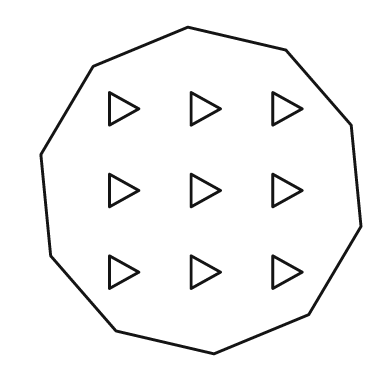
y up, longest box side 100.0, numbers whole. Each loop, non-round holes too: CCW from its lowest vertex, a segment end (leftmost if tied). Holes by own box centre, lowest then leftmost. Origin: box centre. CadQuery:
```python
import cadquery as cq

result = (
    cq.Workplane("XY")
    .moveTo(4.0, -50.0)
    .lineTo(33.0, -38.0)
    .lineTo(49.0, -11.0)
    .lineTo(46.0, 20.0)
    .lineTo(26.0, 43.0)
    .lineTo(-4.0, 50.0)
    .lineTo(-33.0, 38.0)
    .lineTo(-49.0, 11.0)
    .lineTo(-46.0, -20.0)
    .lineTo(-26.0, -43.0)
    .close()
    .moveTo(-28.0, -30.0)
    .lineTo(-19.0, -25.0)
    .lineTo(-28.0, -20.0)
    .close()
    .moveTo(-3.0, -30.0)
    .lineTo(6.0, -25.0)
    .lineTo(-3.0, -20.0)
    .close()
    .moveTo(22.0, -30.0)
    .lineTo(31.0, -25.0)
    .lineTo(22.0, -20.0)
    .close()
    .moveTo(-28.0, -5.0)
    .lineTo(-19.0, 0.0)
    .lineTo(-28.0, 5.0)
    .close()
    .moveTo(-3.0, -5.0)
    .lineTo(6.0, 0.0)
    .lineTo(-3.0, 5.0)
    .close()
    .moveTo(22.0, -5.0)
    .lineTo(31.0, 0.0)
    .lineTo(22.0, 5.0)
    .close()
    .moveTo(-28.0, 20.0)
    .lineTo(-19.0, 25.0)
    .lineTo(-28.0, 30.0)
    .close()
    .moveTo(-3.0, 20.0)
    .lineTo(6.0, 25.0)
    .lineTo(-3.0, 30.0)
    .close()
    .moveTo(22.0, 20.0)
    .lineTo(31.0, 25.0)
    .lineTo(22.0, 30.0)
    .close()
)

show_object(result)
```